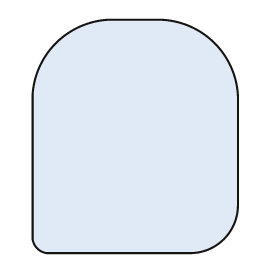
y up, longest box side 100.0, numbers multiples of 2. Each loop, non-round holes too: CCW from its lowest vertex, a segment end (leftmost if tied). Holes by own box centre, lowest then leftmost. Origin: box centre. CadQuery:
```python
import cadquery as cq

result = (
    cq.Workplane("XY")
    .moveTo(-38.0, -50.0)
    .lineTo(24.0, -50.0)
    .threePointArc((38.0, -44.0), (44.0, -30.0))
    .lineTo(44.0, 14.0)
    .threePointArc((34.0, 40.0), (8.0, 50.0))
    .lineTo(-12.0, 50.0)
    .threePointArc((-34.0, 40.0), (-44.0, 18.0))
    .lineTo(-44.0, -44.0)
    .threePointArc((-42.0, -48.0), (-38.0, -50.0))
    .close()
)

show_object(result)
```